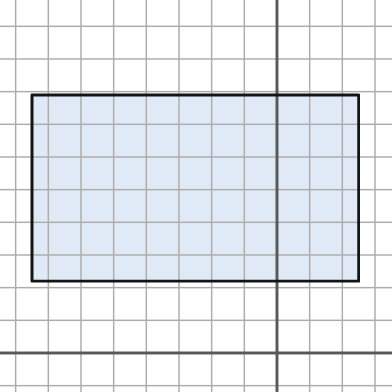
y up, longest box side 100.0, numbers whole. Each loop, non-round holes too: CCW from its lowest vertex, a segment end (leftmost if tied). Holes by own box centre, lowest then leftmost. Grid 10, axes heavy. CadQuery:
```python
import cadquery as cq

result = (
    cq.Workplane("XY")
    .moveTo(-75.0, 22.0)
    .lineTo(25.0, 22.0)
    .lineTo(25.0, 79.0)
    .lineTo(-75.0, 79.0)
    .close()
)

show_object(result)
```